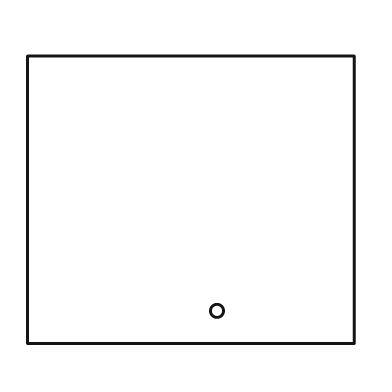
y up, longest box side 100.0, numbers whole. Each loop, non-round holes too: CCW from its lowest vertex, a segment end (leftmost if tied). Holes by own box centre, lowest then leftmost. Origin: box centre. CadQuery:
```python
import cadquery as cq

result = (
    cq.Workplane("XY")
    .moveTo(-50.0, -44.0)
    .lineTo(50.0, -44.0)
    .lineTo(50.0, 44.0)
    .lineTo(-50.0, 44.0)
    .close()
    .moveTo(8.0, -34.0)
    .circle(2.0)
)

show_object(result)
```